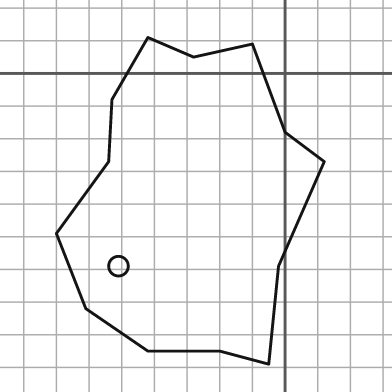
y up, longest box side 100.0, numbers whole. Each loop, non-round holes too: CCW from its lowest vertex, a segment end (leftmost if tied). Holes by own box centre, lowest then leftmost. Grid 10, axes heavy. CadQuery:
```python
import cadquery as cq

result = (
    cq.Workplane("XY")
    .moveTo(-5.0, -89.0)
    .lineTo(-2.0, -59.0)
    .lineTo(12.0, -27.0)
    .lineTo(0.0, -18.0)
    .lineTo(-10.0, 9.0)
    .lineTo(-28.0, 5.0)
    .lineTo(-42.0, 11.0)
    .lineTo(-53.0, -8.0)
    .lineTo(-54.0, -27.0)
    .lineTo(-70.0, -49.0)
    .lineTo(-61.0, -72.0)
    .lineTo(-42.0, -85.0)
    .lineTo(-20.0, -85.0)
    .close()
    .moveTo(-51.0, -59.0)
    .circle(3.0)
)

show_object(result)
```